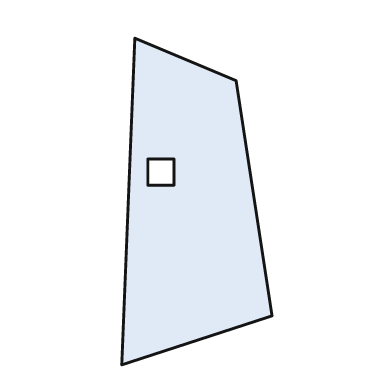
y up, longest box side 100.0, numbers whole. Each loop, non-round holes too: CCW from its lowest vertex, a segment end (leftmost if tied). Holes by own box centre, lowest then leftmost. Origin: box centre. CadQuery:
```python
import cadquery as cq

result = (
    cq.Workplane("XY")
    .moveTo(-23.0, -50.0)
    .lineTo(23.0, -35.0)
    .lineTo(12.0, 37.0)
    .lineTo(-19.0, 50.0)
    .close()
    .moveTo(-15.0, 5.0)
    .lineTo(-7.0, 5.0)
    .lineTo(-7.0, 13.0)
    .lineTo(-15.0, 13.0)
    .close()
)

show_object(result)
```